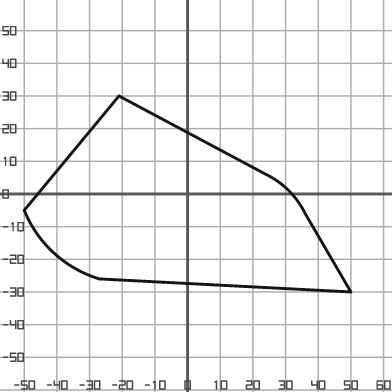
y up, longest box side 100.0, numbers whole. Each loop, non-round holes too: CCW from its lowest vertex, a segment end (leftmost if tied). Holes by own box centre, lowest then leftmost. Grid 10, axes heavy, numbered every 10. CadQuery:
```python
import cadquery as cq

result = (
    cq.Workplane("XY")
    .moveTo(50.0, -30.0)
    .lineTo(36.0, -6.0)
    .threePointArc((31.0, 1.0), (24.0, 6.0))
    .lineTo(-21.0, 30.0)
    .lineTo(-50.0, -5.0)
    .threePointArc((-41.0, -18.0), (-27.0, -26.0))
    .close()
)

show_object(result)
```